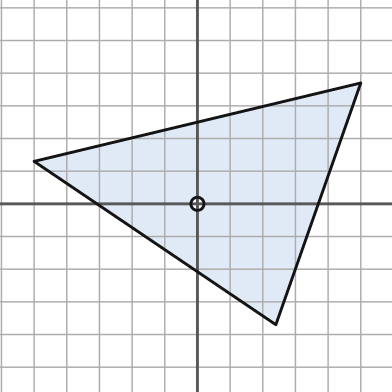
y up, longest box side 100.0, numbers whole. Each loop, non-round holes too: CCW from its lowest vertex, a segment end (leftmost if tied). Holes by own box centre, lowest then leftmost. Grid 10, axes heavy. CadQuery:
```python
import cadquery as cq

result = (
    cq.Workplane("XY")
    .moveTo(24.0, -37.0)
    .lineTo(50.0, 37.0)
    .lineTo(-50.0, 13.0)
    .close()
    .moveTo(0.0, 0.0)
    .circle(2.0)
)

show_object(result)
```